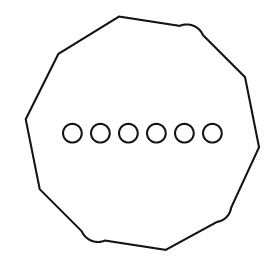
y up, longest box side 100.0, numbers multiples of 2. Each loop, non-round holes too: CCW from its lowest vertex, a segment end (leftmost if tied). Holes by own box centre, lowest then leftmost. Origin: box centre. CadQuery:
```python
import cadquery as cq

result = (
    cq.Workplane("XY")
    .moveTo(10.0, -50.0)
    .lineTo(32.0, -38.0)
    .threePointArc((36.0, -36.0), (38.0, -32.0))
    .lineTo(50.0, -6.0)
    .lineTo(44.0, 24.0)
    .lineTo(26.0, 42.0)
    .threePointArc((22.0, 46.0), (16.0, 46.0))
    .lineTo(-10.0, 50.0)
    .lineTo(-36.0, 34.0)
    .lineTo(-50.0, 6.0)
    .lineTo(-44.0, -24.0)
    .lineTo(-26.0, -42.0)
    .threePointArc((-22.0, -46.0), (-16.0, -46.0))
    .close()
    .moveTo(-30.0, 0.0)
    .circle(4.0)
    .moveTo(-18.0, 0.0)
    .circle(4.0)
    .moveTo(-6.0, 0.0)
    .circle(4.0)
    .moveTo(6.0, 0.0)
    .circle(4.0)
    .moveTo(18.0, 0.0)
    .circle(4.0)
    .moveTo(30.0, 0.0)
    .circle(4.0)
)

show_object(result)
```